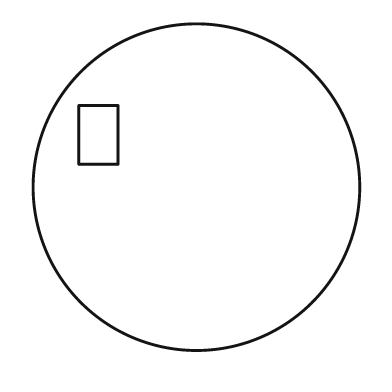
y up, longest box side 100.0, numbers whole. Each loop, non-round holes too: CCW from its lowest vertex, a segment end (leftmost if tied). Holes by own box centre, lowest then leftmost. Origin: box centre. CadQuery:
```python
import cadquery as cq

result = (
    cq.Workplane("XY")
    .moveTo(0.0, 0.0)
    .circle(50.0)
    .moveTo(-36.0, 7.0)
    .lineTo(-24.0, 7.0)
    .lineTo(-24.0, 25.0)
    .lineTo(-36.0, 25.0)
    .close()
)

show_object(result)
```